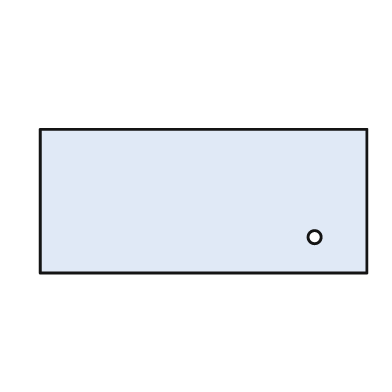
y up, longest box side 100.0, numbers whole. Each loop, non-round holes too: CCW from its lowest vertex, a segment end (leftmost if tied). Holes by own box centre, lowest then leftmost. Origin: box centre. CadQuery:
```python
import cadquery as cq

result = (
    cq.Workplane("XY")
    .moveTo(-50.0, -22.0)
    .lineTo(50.0, -22.0)
    .lineTo(50.0, 22.0)
    .lineTo(-50.0, 22.0)
    .close()
    .moveTo(34.0, -11.0)
    .circle(2.0)
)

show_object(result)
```